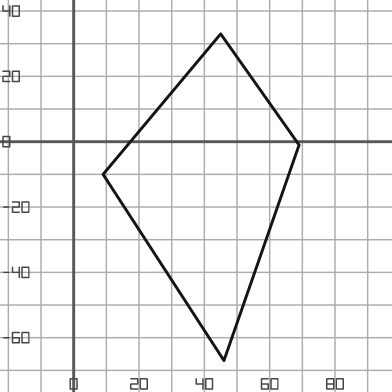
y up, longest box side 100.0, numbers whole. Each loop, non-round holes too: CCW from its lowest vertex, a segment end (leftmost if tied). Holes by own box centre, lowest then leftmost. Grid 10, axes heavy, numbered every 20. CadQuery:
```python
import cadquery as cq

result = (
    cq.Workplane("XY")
    .moveTo(46.0, -67.0)
    .lineTo(69.0, -1.0)
    .lineTo(45.0, 33.0)
    .lineTo(9.0, -10.0)
    .close()
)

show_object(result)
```